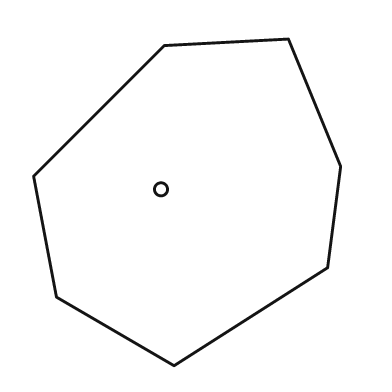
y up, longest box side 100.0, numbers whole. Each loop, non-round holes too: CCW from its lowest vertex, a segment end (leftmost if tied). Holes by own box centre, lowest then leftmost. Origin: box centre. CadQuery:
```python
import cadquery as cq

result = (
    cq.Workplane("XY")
    .moveTo(-4.0, -50.0)
    .lineTo(43.0, -20.0)
    .lineTo(47.0, 11.0)
    .lineTo(31.0, 50.0)
    .lineTo(-7.0, 48.0)
    .lineTo(-47.0, 8.0)
    .lineTo(-40.0, -29.0)
    .close()
    .moveTo(-8.0, 4.0)
    .circle(2.0)
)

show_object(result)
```